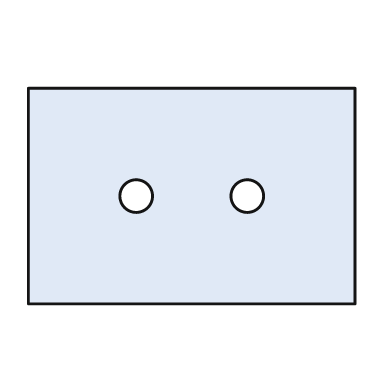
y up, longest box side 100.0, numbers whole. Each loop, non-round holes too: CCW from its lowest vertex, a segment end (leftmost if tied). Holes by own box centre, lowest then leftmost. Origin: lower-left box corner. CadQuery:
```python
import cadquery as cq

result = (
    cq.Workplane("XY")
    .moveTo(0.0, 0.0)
    .lineTo(100.0, 0.0)
    .lineTo(100.0, 66.0)
    .lineTo(0.0, 66.0)
    .close()
    .moveTo(33.0, 33.0)
    .circle(5.0)
    .moveTo(67.0, 33.0)
    .circle(5.0)
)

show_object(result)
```